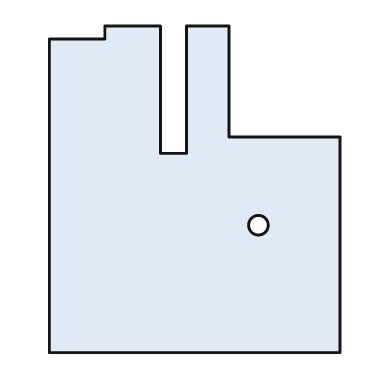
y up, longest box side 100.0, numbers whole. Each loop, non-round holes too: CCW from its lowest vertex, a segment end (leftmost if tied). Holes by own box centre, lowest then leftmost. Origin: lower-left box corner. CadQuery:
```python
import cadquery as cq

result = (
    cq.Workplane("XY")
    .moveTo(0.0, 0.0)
    .lineTo(89.0, 0.0)
    .lineTo(89.0, 66.0)
    .lineTo(55.0, 66.0)
    .lineTo(55.0, 100.0)
    .lineTo(42.0, 100.0)
    .lineTo(42.0, 61.0)
    .lineTo(34.0, 61.0)
    .lineTo(34.0, 100.0)
    .lineTo(17.0, 100.0)
    .lineTo(17.0, 96.0)
    .lineTo(0.0, 96.0)
    .close()
    .moveTo(64.0, 39.0)
    .circle(3.0)
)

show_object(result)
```